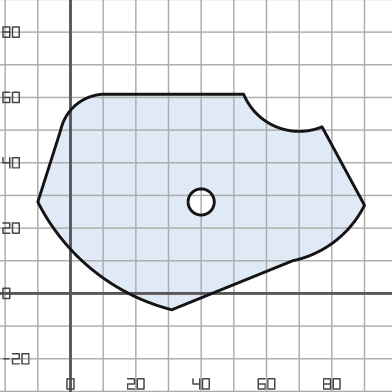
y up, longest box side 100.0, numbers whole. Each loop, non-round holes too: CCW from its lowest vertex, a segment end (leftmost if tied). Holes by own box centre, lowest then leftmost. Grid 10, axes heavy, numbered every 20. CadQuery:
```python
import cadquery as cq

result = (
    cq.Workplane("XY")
    .moveTo(31.0, -5.0)
    .lineTo(68.0, 10.0)
    .threePointArc((81.0, 16.0), (90.0, 27.0))
    .lineTo(77.0, 51.0)
    .threePointArc((63.0, 51.0), (53.0, 61.0))
    .lineTo(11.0, 61.0)
    .threePointArc((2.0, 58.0), (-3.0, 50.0))
    .lineTo(-10.0, 28.0)
    .threePointArc((7.0, 7.0), (31.0, -5.0))
    .close()
    .moveTo(40.0, 28.0)
    .circle(4.0)
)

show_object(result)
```